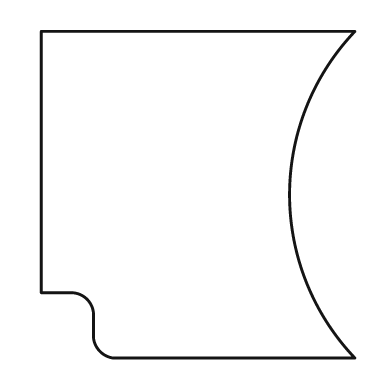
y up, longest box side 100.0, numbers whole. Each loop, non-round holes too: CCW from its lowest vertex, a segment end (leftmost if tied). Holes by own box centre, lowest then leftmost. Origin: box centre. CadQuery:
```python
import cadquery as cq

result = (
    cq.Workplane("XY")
    .moveTo(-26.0, -50.0)
    .lineTo(48.0, -50.0)
    .threePointArc((28.0, 0.0), (48.0, 50.0))
    .lineTo(-48.0, 50.0)
    .lineTo(-48.0, -30.0)
    .lineTo(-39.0, -30.0)
    .threePointArc((-34.0, -32.0), (-32.0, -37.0))
    .lineTo(-32.0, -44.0)
    .threePointArc((-30.0, -48.0), (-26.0, -50.0))
    .close()
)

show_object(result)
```